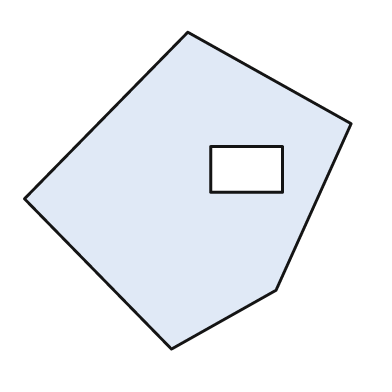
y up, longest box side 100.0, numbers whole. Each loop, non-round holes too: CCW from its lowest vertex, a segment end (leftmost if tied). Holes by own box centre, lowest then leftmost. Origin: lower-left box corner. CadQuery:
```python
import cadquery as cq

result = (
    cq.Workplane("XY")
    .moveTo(45.0, 0.0)
    .lineTo(77.0, 18.0)
    .lineTo(100.0, 69.0)
    .lineTo(50.0, 97.0)
    .lineTo(0.0, 46.0)
    .close()
    .moveTo(57.0, 48.0)
    .lineTo(79.0, 48.0)
    .lineTo(79.0, 62.0)
    .lineTo(57.0, 62.0)
    .close()
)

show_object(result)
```